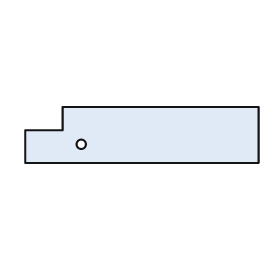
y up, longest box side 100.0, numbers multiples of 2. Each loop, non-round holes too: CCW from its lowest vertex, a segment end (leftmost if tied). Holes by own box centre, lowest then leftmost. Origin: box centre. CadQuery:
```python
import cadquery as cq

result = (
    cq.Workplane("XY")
    .moveTo(-50.0, -12.0)
    .lineTo(50.0, -12.0)
    .lineTo(50.0, 12.0)
    .lineTo(-34.0, 12.0)
    .lineTo(-34.0, 2.0)
    .lineTo(-50.0, 2.0)
    .close()
    .moveTo(-26.0, -4.0)
    .circle(2.0)
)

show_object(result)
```